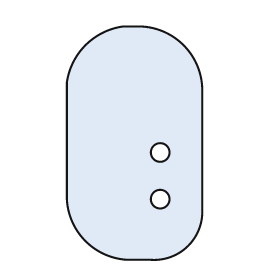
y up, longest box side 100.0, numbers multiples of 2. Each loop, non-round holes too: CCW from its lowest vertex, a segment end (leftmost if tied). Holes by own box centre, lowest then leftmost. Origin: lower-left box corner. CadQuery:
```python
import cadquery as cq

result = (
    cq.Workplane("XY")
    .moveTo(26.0, 0.0)
    .lineTo(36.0, 0.0)
    .threePointArc((52.0, 6.0), (58.0, 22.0))
    .lineTo(58.0, 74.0)
    .threePointArc((50.0, 92.0), (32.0, 100.0))
    .lineTo(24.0, 100.0)
    .threePointArc((8.0, 92.0), (0.0, 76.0))
    .lineTo(0.0, 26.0)
    .threePointArc((8.0, 8.0), (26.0, 0.0))
    .close()
    .moveTo(40.0, 26.0)
    .circle(4.0)
    .moveTo(40.0, 46.0)
    .circle(4.0)
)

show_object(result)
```